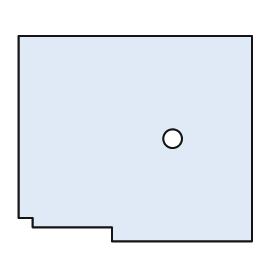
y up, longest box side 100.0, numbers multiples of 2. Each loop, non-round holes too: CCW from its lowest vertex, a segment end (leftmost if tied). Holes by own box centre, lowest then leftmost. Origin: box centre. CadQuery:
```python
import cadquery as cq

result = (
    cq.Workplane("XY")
    .moveTo(-10.0, -44.0)
    .lineTo(50.0, -44.0)
    .lineTo(50.0, 44.0)
    .lineTo(-50.0, 44.0)
    .lineTo(-50.0, -34.0)
    .lineTo(-44.0, -34.0)
    .lineTo(-44.0, -38.0)
    .lineTo(-10.0, -38.0)
    .close()
    .moveTo(16.0, 0.0)
    .circle(4.0)
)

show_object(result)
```